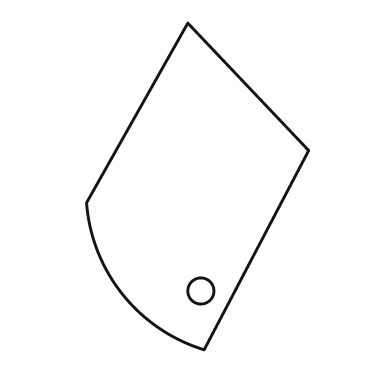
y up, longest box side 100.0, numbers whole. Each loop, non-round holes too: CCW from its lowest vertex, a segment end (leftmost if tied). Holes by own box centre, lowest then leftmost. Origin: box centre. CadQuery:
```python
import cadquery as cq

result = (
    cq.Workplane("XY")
    .moveTo(2.0, -50.0)
    .lineTo(34.0, 11.0)
    .lineTo(-3.0, 50.0)
    .lineTo(-34.0, -5.0)
    .threePointArc((-23.0, -33.0), (2.0, -50.0))
    .close()
    .moveTo(1.0, -32.0)
    .circle(4.0)
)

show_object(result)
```